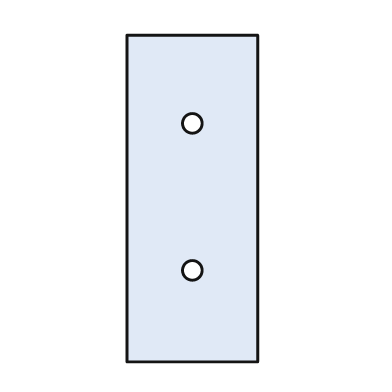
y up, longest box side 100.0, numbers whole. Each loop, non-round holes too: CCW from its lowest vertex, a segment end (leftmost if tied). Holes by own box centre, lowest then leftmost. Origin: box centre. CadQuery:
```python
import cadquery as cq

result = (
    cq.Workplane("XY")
    .moveTo(-20.0, -50.0)
    .lineTo(20.0, -50.0)
    .lineTo(20.0, 50.0)
    .lineTo(-20.0, 50.0)
    .close()
    .moveTo(0.0, -22.0)
    .circle(3.0)
    .moveTo(0.0, 23.0)
    .circle(3.0)
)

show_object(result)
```